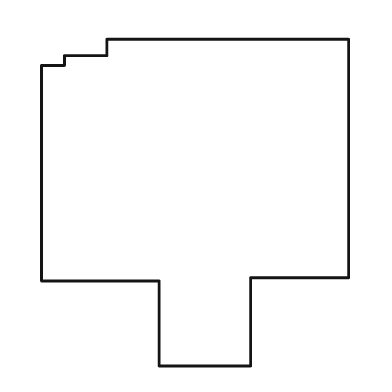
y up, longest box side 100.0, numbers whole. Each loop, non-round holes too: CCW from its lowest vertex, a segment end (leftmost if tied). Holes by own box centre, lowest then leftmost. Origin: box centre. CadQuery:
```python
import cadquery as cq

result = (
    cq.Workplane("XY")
    .moveTo(-11.0, -50.0)
    .lineTo(17.0, -50.0)
    .lineTo(17.0, -23.0)
    .lineTo(47.0, -23.0)
    .lineTo(47.0, 50.0)
    .lineTo(-27.0, 50.0)
    .lineTo(-27.0, 45.0)
    .lineTo(-40.0, 45.0)
    .lineTo(-40.0, 42.0)
    .lineTo(-47.0, 42.0)
    .lineTo(-47.0, -24.0)
    .lineTo(-11.0, -24.0)
    .close()
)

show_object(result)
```